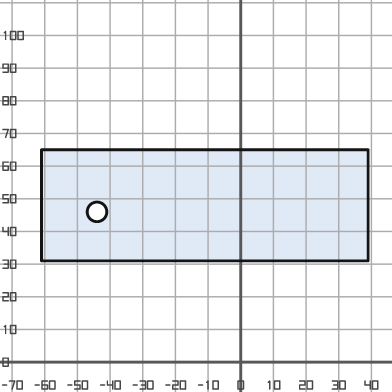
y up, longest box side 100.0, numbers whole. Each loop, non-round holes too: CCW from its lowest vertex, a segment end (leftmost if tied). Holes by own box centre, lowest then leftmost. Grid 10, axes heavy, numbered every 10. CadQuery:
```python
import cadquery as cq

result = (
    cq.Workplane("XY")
    .moveTo(-61.0, 31.0)
    .lineTo(39.0, 31.0)
    .lineTo(39.0, 65.0)
    .lineTo(-61.0, 65.0)
    .close()
    .moveTo(-44.0, 46.0)
    .circle(3.0)
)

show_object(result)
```